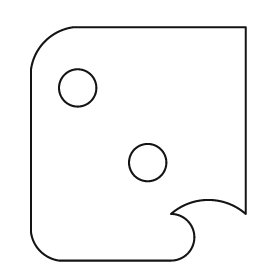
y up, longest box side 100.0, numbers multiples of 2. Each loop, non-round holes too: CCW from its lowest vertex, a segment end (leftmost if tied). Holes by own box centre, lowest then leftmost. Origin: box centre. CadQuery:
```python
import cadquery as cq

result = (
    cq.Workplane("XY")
    .moveTo(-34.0, -50.0)
    .lineTo(14.0, -50.0)
    .threePointArc((24.0, -40.0), (14.0, -30.0))
    .threePointArc((30.0, -24.0), (46.0, -30.0))
    .lineTo(46.0, 50.0)
    .lineTo(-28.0, 50.0)
    .threePointArc((-40.0, 44.0), (-46.0, 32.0))
    .lineTo(-46.0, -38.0)
    .threePointArc((-42.0, -46.0), (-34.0, -50.0))
    .close()
    .moveTo(4.0, -8.0)
    .circle(8.0)
    .moveTo(-26.0, 24.0)
    .circle(8.0)
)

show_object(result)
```